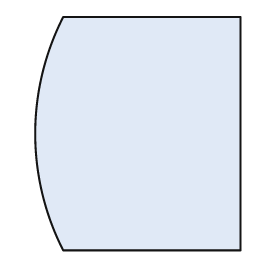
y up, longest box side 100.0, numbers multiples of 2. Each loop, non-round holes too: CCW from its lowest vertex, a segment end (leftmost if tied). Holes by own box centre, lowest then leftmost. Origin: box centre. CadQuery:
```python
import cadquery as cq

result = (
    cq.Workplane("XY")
    .moveTo(-32.0, -50.0)
    .lineTo(44.0, -50.0)
    .lineTo(44.0, 50.0)
    .lineTo(-32.0, 50.0)
    .threePointArc((-44.0, 0.0), (-32.0, -50.0))
    .close()
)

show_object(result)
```